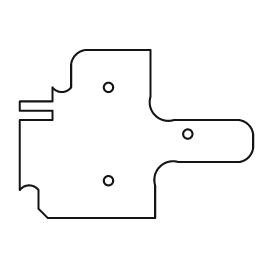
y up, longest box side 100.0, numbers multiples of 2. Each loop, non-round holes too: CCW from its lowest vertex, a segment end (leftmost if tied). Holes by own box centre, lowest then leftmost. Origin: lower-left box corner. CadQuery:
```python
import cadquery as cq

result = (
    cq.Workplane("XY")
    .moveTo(12.0, 0.0)
    .lineTo(58.0, 0.0)
    .lineTo(58.0, 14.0)
    .threePointArc((60.0, 22.0), (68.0, 24.0))
    .lineTo(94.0, 24.0)
    .threePointArc((98.0, 26.0), (100.0, 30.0))
    .lineTo(100.0, 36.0)
    .threePointArc((98.0, 40.0), (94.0, 42.0))
    .lineTo(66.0, 42.0)
    .threePointArc((58.0, 44.0), (56.0, 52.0))
    .lineTo(56.0, 72.0)
    .lineTo(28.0, 72.0)
    .threePointArc((24.0, 70.0), (22.0, 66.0))
    .lineTo(22.0, 56.0)
    .threePointArc((18.0, 54.0), (14.0, 56.0))
    .lineTo(14.0, 50.0)
    .lineTo(0.0, 50.0)
    .lineTo(0.0, 46.0)
    .lineTo(14.0, 46.0)
    .lineTo(14.0, 42.0)
    .lineTo(0.0, 42.0)
    .lineTo(0.0, 12.0)
    .threePointArc((4.0, 14.0), (8.0, 12.0))
    .lineTo(8.0, 4.0)
    .close()
    .moveTo(38.0, 16.0)
    .circle(2.0)
    .moveTo(72.0, 36.0)
    .circle(2.0)
    .moveTo(38.0, 56.0)
    .circle(2.0)
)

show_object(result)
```